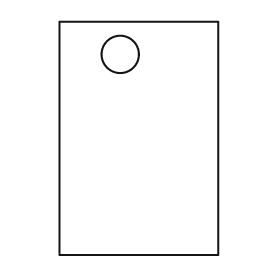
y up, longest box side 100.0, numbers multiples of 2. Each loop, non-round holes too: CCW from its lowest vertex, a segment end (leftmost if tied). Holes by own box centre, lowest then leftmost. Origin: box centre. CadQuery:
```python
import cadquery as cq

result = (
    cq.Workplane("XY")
    .moveTo(-34.0, -50.0)
    .lineTo(34.0, -50.0)
    .lineTo(34.0, 50.0)
    .lineTo(-34.0, 50.0)
    .close()
    .moveTo(-8.0, 36.0)
    .circle(8.0)
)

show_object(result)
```